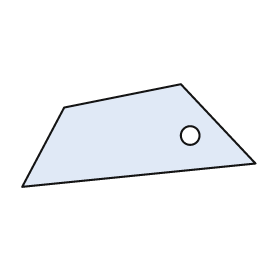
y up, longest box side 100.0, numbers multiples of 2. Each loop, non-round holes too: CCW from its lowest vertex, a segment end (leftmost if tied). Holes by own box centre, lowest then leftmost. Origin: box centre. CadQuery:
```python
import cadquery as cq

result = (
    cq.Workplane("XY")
    .moveTo(-50.0, -22.0)
    .lineTo(50.0, -12.0)
    .lineTo(18.0, 22.0)
    .lineTo(-32.0, 12.0)
    .close()
    .moveTo(22.0, 0.0)
    .circle(4.0)
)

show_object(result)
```